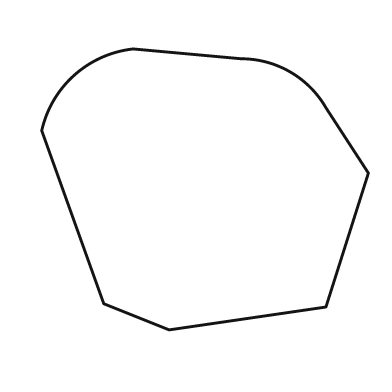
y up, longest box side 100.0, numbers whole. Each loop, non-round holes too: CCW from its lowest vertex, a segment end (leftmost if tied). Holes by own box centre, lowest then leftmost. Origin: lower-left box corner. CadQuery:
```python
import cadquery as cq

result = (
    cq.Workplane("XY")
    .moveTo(39.0, 0.0)
    .lineTo(87.0, 7.0)
    .lineTo(100.0, 48.0)
    .lineTo(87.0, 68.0)
    .threePointArc((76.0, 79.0), (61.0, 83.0))
    .lineTo(28.0, 86.0)
    .threePointArc((10.0, 78.0), (0.0, 61.0))
    .lineTo(19.0, 8.0)
    .close()
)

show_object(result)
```